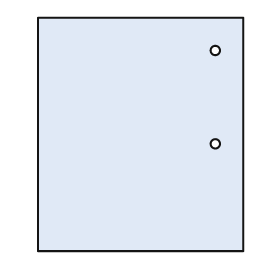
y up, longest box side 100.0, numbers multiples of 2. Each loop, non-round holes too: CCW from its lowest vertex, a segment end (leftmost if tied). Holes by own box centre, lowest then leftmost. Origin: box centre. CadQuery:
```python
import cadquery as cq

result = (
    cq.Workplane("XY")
    .moveTo(-44.0, -50.0)
    .lineTo(44.0, -50.0)
    .lineTo(44.0, 50.0)
    .lineTo(-44.0, 50.0)
    .close()
    .moveTo(32.0, -4.0)
    .circle(2.0)
    .moveTo(32.0, 36.0)
    .circle(2.0)
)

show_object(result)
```